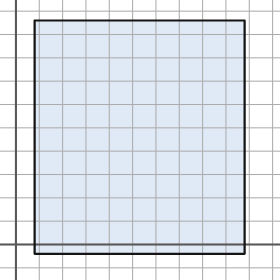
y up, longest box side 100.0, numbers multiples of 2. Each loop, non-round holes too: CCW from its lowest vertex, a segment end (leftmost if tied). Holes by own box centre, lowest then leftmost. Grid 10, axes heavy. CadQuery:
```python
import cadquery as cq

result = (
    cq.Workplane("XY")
    .moveTo(8.0, -4.0)
    .lineTo(98.0, -4.0)
    .lineTo(98.0, 96.0)
    .lineTo(8.0, 96.0)
    .close()
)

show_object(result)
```